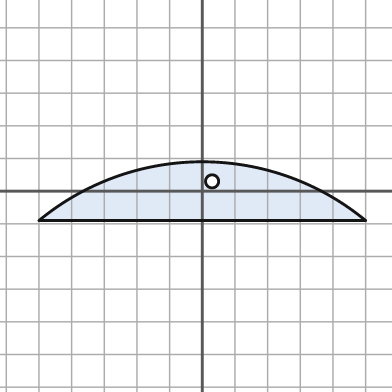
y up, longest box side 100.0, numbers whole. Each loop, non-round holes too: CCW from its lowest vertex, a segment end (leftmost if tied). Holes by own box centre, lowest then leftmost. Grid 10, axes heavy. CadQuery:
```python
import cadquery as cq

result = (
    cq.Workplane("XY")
    .moveTo(-50.0, -9.0)
    .lineTo(50.0, -9.0)
    .threePointArc((0.0, 9.0), (-50.0, -9.0))
    .close()
    .moveTo(3.0, 3.0)
    .circle(2.0)
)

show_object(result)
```